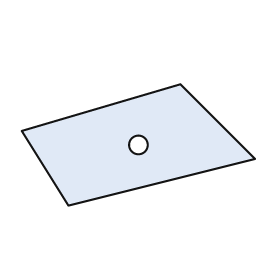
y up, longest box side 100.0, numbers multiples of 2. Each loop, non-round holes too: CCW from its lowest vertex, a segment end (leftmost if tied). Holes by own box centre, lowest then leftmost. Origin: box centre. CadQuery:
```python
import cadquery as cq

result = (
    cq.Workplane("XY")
    .moveTo(-30.0, -26.0)
    .lineTo(50.0, -6.0)
    .lineTo(18.0, 26.0)
    .lineTo(-50.0, 6.0)
    .close()
    .moveTo(0.0, 0.0)
    .circle(4.0)
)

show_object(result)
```